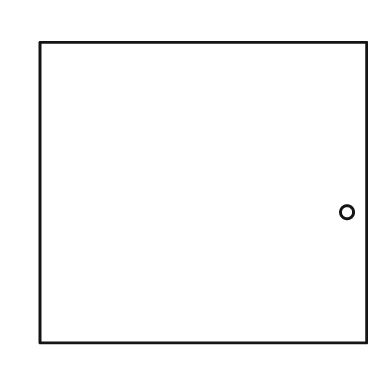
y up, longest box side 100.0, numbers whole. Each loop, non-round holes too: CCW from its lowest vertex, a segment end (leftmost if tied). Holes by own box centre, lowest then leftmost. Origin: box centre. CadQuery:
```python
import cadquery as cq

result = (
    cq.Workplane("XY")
    .moveTo(-50.0, -46.0)
    .lineTo(50.0, -46.0)
    .lineTo(50.0, 46.0)
    .lineTo(-50.0, 46.0)
    .close()
    .moveTo(44.0, -6.0)
    .circle(2.0)
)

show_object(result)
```